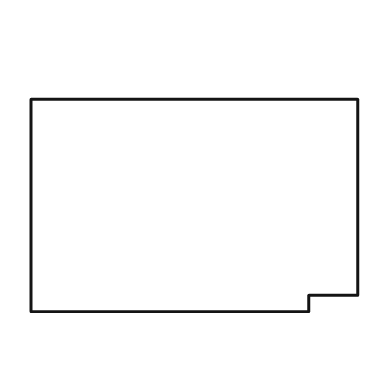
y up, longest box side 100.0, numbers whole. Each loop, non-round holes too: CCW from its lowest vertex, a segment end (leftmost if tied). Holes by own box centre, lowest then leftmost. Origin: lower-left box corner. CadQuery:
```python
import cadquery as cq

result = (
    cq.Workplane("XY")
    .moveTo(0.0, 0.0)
    .lineTo(85.0, 0.0)
    .lineTo(85.0, 5.0)
    .lineTo(100.0, 5.0)
    .lineTo(100.0, 65.0)
    .lineTo(0.0, 65.0)
    .close()
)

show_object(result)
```